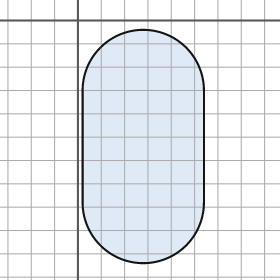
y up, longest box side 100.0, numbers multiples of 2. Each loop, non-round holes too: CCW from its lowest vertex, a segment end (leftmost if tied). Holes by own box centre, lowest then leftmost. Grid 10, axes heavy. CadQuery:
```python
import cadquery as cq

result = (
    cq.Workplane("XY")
    .moveTo(2.0, -78.0)
    .threePointArc((28.0, -104.0), (54.0, -78.0))
    .lineTo(54.0, -30.0)
    .threePointArc((28.0, -4.0), (2.0, -30.0))
    .close()
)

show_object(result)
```